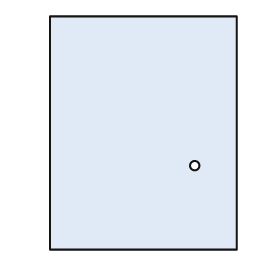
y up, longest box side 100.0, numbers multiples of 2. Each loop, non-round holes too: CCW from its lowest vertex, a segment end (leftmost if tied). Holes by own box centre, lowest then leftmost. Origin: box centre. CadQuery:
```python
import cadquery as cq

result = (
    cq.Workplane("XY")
    .moveTo(-40.0, -50.0)
    .lineTo(40.0, -50.0)
    .lineTo(40.0, 50.0)
    .lineTo(-40.0, 50.0)
    .close()
    .moveTo(22.0, -14.0)
    .circle(2.0)
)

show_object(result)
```